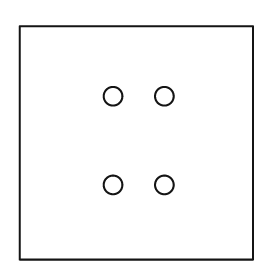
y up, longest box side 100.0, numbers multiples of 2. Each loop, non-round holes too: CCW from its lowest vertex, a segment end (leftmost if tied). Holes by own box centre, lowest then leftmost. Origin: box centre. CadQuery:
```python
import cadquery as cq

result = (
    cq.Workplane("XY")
    .moveTo(-50.0, -50.0)
    .lineTo(50.0, -50.0)
    .lineTo(50.0, 50.0)
    .lineTo(-50.0, 50.0)
    .close()
    .moveTo(-10.0, -18.0)
    .circle(4.0)
    .moveTo(12.0, -18.0)
    .circle(4.0)
    .moveTo(-10.0, 20.0)
    .circle(4.0)
    .moveTo(12.0, 20.0)
    .circle(4.0)
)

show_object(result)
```